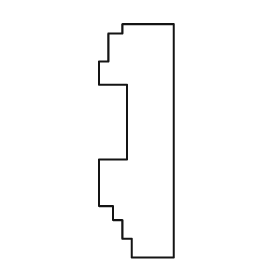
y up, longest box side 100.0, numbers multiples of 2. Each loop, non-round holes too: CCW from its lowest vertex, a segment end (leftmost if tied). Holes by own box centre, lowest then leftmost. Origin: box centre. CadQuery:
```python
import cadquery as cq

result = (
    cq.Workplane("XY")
    .moveTo(-2.0, -50.0)
    .lineTo(16.0, -50.0)
    .lineTo(16.0, 50.0)
    .lineTo(-6.0, 50.0)
    .lineTo(-6.0, 46.0)
    .lineTo(-12.0, 46.0)
    .lineTo(-12.0, 34.0)
    .lineTo(-16.0, 34.0)
    .lineTo(-16.0, 24.0)
    .lineTo(-4.0, 24.0)
    .lineTo(-4.0, -8.0)
    .lineTo(-16.0, -8.0)
    .lineTo(-16.0, -28.0)
    .lineTo(-10.0, -28.0)
    .lineTo(-10.0, -34.0)
    .lineTo(-6.0, -34.0)
    .lineTo(-6.0, -42.0)
    .lineTo(-2.0, -42.0)
    .close()
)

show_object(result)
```